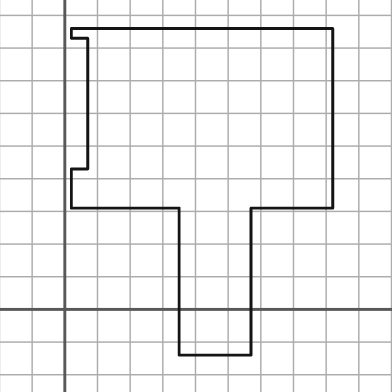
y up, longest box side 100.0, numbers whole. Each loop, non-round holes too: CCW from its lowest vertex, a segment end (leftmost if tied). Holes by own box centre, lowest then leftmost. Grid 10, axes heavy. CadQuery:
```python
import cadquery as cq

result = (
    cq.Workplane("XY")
    .moveTo(35.0, -14.0)
    .lineTo(57.0, -14.0)
    .lineTo(57.0, 31.0)
    .lineTo(82.0, 31.0)
    .lineTo(82.0, 86.0)
    .lineTo(2.0, 86.0)
    .lineTo(2.0, 83.0)
    .lineTo(7.0, 83.0)
    .lineTo(7.0, 43.0)
    .lineTo(2.0, 43.0)
    .lineTo(2.0, 31.0)
    .lineTo(35.0, 31.0)
    .close()
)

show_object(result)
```